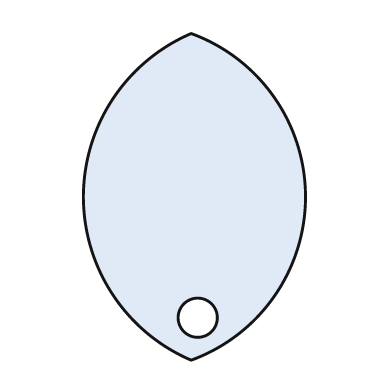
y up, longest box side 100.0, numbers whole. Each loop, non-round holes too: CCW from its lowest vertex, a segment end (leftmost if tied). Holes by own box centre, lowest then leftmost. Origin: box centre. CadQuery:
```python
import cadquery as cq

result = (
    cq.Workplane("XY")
    .moveTo(-1.0, -50.0)
    .threePointArc((34.0, 0.0), (-1.0, 50.0))
    .threePointArc((-34.0, 0.0), (-1.0, -50.0))
    .close()
    .moveTo(1.0, -37.0)
    .circle(6.0)
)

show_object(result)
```